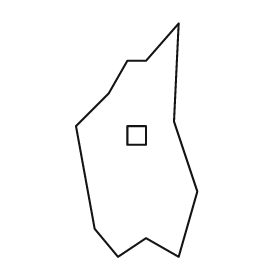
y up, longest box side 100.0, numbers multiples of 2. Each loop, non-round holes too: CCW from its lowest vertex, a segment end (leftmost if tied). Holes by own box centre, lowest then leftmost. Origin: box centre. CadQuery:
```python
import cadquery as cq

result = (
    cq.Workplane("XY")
    .moveTo(-8.0, -50.0)
    .lineTo(4.0, -42.0)
    .lineTo(18.0, -50.0)
    .lineTo(26.0, -22.0)
    .lineTo(16.0, 8.0)
    .lineTo(18.0, 50.0)
    .lineTo(4.0, 34.0)
    .lineTo(-4.0, 34.0)
    .lineTo(-12.0, 20.0)
    .lineTo(-26.0, 6.0)
    .lineTo(-18.0, -38.0)
    .close()
    .moveTo(-4.0, -2.0)
    .lineTo(4.0, -2.0)
    .lineTo(4.0, 6.0)
    .lineTo(-4.0, 6.0)
    .close()
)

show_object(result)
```